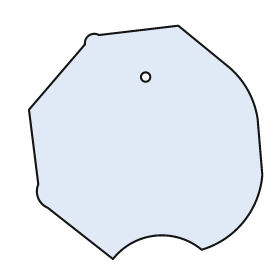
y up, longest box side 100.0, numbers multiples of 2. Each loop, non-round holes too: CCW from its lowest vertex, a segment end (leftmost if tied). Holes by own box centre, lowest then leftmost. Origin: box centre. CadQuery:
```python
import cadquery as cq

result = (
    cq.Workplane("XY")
    .moveTo(-14.0, -50.0)
    .threePointArc((4.0, -40.0), (24.0, -46.0))
    .threePointArc((42.0, -34.0), (50.0, -14.0))
    .lineTo(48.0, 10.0)
    .threePointArc((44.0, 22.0), (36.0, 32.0))
    .lineTo(14.0, 50.0)
    .lineTo(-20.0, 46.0)
    .threePointArc((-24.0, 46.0), (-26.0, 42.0))
    .lineTo(-50.0, 14.0)
    .lineTo(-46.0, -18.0)
    .threePointArc((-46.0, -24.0), (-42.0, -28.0))
    .close()
    .moveTo(0.0, 28.0)
    .circle(2.0)
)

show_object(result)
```